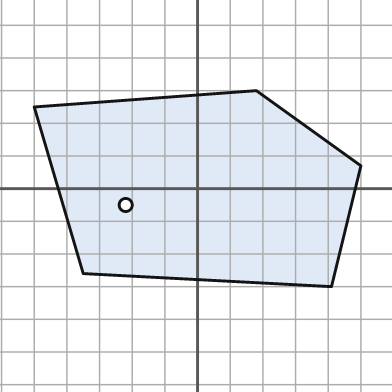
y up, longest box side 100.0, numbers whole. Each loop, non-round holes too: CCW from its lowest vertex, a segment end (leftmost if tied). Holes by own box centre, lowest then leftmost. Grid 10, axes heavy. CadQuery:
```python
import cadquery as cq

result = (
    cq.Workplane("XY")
    .moveTo(41.0, -30.0)
    .lineTo(50.0, 7.0)
    .lineTo(18.0, 30.0)
    .lineTo(-50.0, 25.0)
    .lineTo(-35.0, -26.0)
    .close()
    .moveTo(-22.0, -5.0)
    .circle(2.0)
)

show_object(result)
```